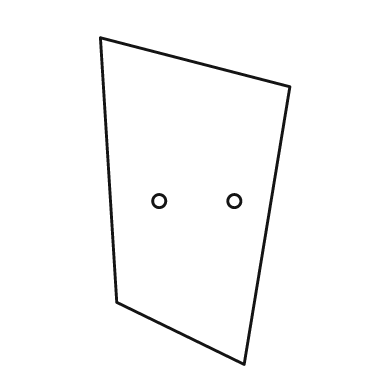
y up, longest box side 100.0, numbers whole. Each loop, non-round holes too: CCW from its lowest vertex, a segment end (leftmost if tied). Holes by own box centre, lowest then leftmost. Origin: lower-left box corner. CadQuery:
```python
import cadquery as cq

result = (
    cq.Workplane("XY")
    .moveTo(44.0, 0.0)
    .lineTo(58.0, 85.0)
    .lineTo(0.0, 100.0)
    .lineTo(5.0, 19.0)
    .close()
    .moveTo(18.0, 50.0)
    .circle(2.0)
    .moveTo(41.0, 50.0)
    .circle(2.0)
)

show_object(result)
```